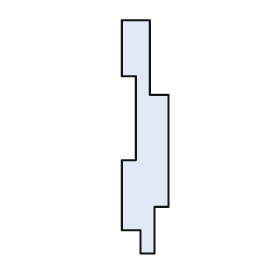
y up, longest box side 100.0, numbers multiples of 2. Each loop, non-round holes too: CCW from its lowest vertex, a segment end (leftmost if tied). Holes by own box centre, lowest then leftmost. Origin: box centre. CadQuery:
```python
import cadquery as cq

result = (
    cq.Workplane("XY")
    .moveTo(-2.0, -50.0)
    .lineTo(4.0, -50.0)
    .lineTo(4.0, -30.0)
    .lineTo(10.0, -30.0)
    .lineTo(10.0, 18.0)
    .lineTo(2.0, 18.0)
    .lineTo(2.0, 50.0)
    .lineTo(-10.0, 50.0)
    .lineTo(-10.0, 26.0)
    .lineTo(-4.0, 26.0)
    .lineTo(-4.0, -10.0)
    .lineTo(-10.0, -10.0)
    .lineTo(-10.0, -40.0)
    .lineTo(-2.0, -40.0)
    .close()
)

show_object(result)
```